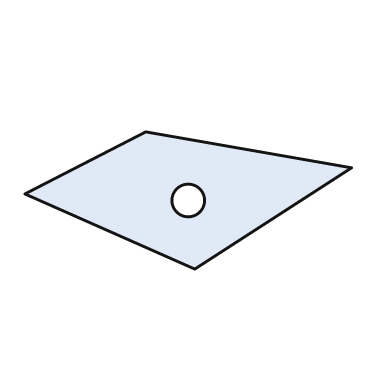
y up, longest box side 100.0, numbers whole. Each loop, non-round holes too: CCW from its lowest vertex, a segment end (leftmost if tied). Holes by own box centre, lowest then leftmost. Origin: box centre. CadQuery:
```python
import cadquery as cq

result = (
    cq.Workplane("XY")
    .moveTo(2.0, -21.0)
    .lineTo(50.0, 10.0)
    .lineTo(-13.0, 21.0)
    .lineTo(-50.0, 2.0)
    .close()
    .moveTo(0.0, 0.0)
    .circle(5.0)
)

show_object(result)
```